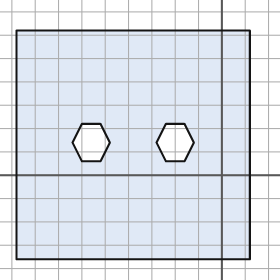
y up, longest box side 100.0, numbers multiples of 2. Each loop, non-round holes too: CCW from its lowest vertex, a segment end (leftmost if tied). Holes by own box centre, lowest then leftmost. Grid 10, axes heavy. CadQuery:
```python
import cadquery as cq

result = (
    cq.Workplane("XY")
    .moveTo(-88.0, -36.0)
    .lineTo(12.0, -36.0)
    .lineTo(12.0, 62.0)
    .lineTo(-88.0, 62.0)
    .close()
    .moveTo(-60.0, 6.0)
    .lineTo(-52.0, 6.0)
    .lineTo(-48.0, 14.0)
    .lineTo(-52.0, 22.0)
    .lineTo(-60.0, 22.0)
    .lineTo(-64.0, 14.0)
    .close()
    .moveTo(-24.0, 6.0)
    .lineTo(-16.0, 6.0)
    .lineTo(-12.0, 14.0)
    .lineTo(-16.0, 22.0)
    .lineTo(-24.0, 22.0)
    .lineTo(-28.0, 14.0)
    .close()
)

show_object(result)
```